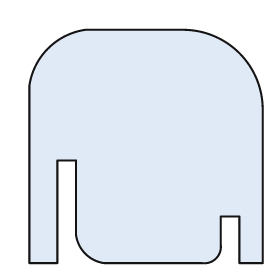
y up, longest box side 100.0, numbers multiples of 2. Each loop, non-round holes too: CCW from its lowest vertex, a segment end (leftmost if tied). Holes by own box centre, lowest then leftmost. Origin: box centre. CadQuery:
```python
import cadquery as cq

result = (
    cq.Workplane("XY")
    .moveTo(-50.0, -50.0)
    .lineTo(-38.0, -50.0)
    .lineTo(-38.0, -6.0)
    .lineTo(-30.0, -6.0)
    .lineTo(-30.0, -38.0)
    .threePointArc((-26.0, -46.0), (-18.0, -50.0))
    .lineTo(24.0, -50.0)
    .threePointArc((30.0, -48.0), (32.0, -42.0))
    .lineTo(32.0, -30.0)
    .lineTo(40.0, -30.0)
    .lineTo(40.0, -50.0)
    .lineTo(50.0, -50.0)
    .lineTo(50.0, 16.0)
    .threePointArc((40.0, 40.0), (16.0, 50.0))
    .lineTo(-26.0, 50.0)
    .threePointArc((-42.0, 42.0), (-50.0, 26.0))
    .close()
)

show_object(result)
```